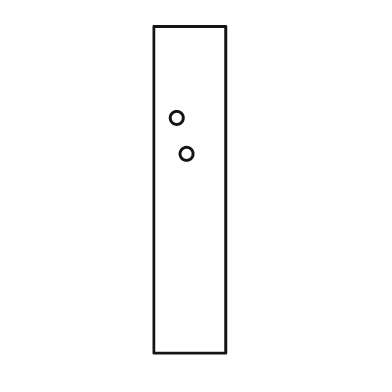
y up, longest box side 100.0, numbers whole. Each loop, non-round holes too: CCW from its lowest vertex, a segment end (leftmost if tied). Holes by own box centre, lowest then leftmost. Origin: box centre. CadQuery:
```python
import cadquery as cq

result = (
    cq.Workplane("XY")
    .moveTo(-11.0, -50.0)
    .lineTo(11.0, -50.0)
    .lineTo(11.0, 50.0)
    .lineTo(-11.0, 50.0)
    .close()
    .moveTo(-1.0, 11.0)
    .circle(2.0)
    .moveTo(-4.0, 22.0)
    .circle(2.0)
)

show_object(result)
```